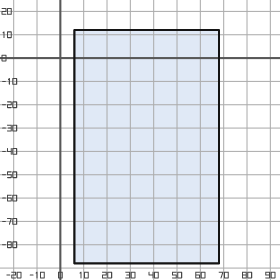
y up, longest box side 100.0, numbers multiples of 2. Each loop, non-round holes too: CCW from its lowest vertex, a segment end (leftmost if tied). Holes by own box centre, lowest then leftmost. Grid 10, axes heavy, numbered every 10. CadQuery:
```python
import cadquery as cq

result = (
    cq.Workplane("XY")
    .moveTo(6.0, -88.0)
    .lineTo(68.0, -88.0)
    .lineTo(68.0, 12.0)
    .lineTo(6.0, 12.0)
    .close()
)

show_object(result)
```